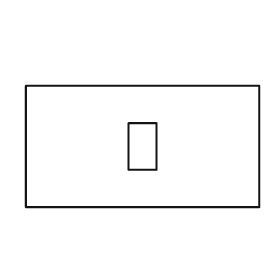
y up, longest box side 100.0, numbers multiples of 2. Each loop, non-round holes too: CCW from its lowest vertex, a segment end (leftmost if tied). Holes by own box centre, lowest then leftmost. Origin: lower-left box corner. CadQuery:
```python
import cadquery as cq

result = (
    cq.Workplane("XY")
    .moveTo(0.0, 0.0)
    .lineTo(100.0, 0.0)
    .lineTo(100.0, 52.0)
    .lineTo(0.0, 52.0)
    .close()
    .moveTo(44.0, 16.0)
    .lineTo(56.0, 16.0)
    .lineTo(56.0, 36.0)
    .lineTo(44.0, 36.0)
    .close()
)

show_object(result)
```